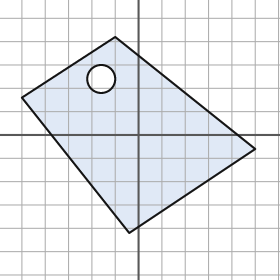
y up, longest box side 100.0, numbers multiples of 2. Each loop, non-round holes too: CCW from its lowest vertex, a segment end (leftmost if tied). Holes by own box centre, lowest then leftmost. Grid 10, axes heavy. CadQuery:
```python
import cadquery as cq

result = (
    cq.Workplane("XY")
    .moveTo(-4.0, -42.0)
    .lineTo(50.0, -6.0)
    .lineTo(-10.0, 42.0)
    .lineTo(-50.0, 16.0)
    .close()
    .moveTo(-16.0, 24.0)
    .circle(6.0)
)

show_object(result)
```